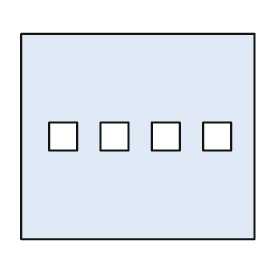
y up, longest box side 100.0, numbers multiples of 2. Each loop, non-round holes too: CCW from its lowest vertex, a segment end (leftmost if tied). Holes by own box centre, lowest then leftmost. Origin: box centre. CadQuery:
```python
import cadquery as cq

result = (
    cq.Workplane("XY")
    .moveTo(-50.0, -44.0)
    .lineTo(50.0, -44.0)
    .lineTo(50.0, 44.0)
    .lineTo(-50.0, 44.0)
    .close()
    .moveTo(-38.0, -6.0)
    .lineTo(-26.0, -6.0)
    .lineTo(-26.0, 6.0)
    .lineTo(-38.0, 6.0)
    .close()
    .moveTo(-16.0, -6.0)
    .lineTo(-4.0, -6.0)
    .lineTo(-4.0, 6.0)
    .lineTo(-16.0, 6.0)
    .close()
    .moveTo(6.0, -6.0)
    .lineTo(18.0, -6.0)
    .lineTo(18.0, 6.0)
    .lineTo(6.0, 6.0)
    .close()
    .moveTo(28.0, -6.0)
    .lineTo(40.0, -6.0)
    .lineTo(40.0, 6.0)
    .lineTo(28.0, 6.0)
    .close()
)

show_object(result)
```